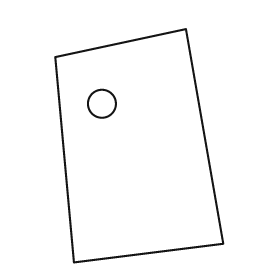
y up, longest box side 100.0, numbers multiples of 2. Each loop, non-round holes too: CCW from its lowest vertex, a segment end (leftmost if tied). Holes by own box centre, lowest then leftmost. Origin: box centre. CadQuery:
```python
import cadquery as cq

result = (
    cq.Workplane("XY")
    .moveTo(-28.0, -50.0)
    .lineTo(36.0, -42.0)
    .lineTo(20.0, 50.0)
    .lineTo(-36.0, 38.0)
    .close()
    .moveTo(-16.0, 18.0)
    .circle(6.0)
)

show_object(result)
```